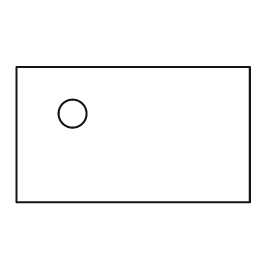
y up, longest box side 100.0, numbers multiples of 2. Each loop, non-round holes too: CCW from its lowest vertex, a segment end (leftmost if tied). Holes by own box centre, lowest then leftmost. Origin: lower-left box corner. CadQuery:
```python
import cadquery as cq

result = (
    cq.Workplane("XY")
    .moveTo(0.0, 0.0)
    .lineTo(100.0, 0.0)
    .lineTo(100.0, 58.0)
    .lineTo(0.0, 58.0)
    .close()
    .moveTo(24.0, 38.0)
    .circle(6.0)
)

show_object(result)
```